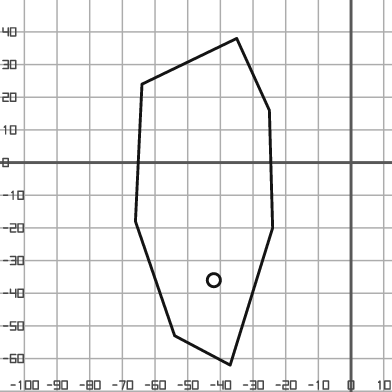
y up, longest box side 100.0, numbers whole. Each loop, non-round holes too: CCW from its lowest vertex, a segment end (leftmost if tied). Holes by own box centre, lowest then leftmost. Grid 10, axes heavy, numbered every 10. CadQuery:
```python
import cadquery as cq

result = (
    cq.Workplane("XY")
    .moveTo(-37.0, -62.0)
    .lineTo(-24.0, -20.0)
    .lineTo(-25.0, 16.0)
    .lineTo(-35.0, 38.0)
    .lineTo(-64.0, 24.0)
    .lineTo(-66.0, -18.0)
    .lineTo(-54.0, -53.0)
    .close()
    .moveTo(-42.0, -36.0)
    .circle(2.0)
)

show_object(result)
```